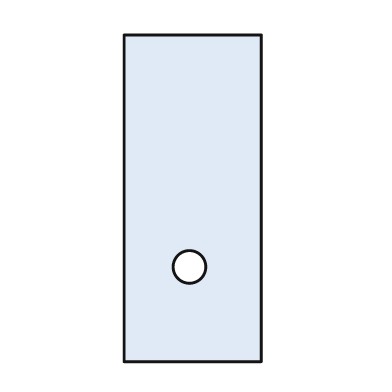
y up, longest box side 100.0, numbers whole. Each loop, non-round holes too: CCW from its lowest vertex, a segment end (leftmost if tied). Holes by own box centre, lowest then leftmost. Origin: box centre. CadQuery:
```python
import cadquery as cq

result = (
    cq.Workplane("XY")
    .moveTo(-21.0, -50.0)
    .lineTo(21.0, -50.0)
    .lineTo(21.0, 50.0)
    .lineTo(-21.0, 50.0)
    .close()
    .moveTo(-1.0, -21.0)
    .circle(5.0)
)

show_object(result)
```